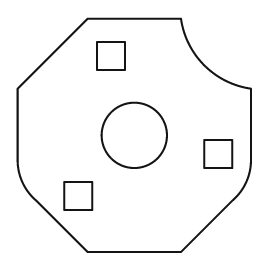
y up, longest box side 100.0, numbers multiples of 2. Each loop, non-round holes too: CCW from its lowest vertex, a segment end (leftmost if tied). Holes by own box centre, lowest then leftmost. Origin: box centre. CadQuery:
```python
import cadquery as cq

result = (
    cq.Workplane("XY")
    .moveTo(-20.0, -50.0)
    .lineTo(20.0, -50.0)
    .lineTo(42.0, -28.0)
    .threePointArc((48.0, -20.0), (50.0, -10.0))
    .lineTo(50.0, 20.0)
    .threePointArc((30.0, 30.0), (20.0, 50.0))
    .lineTo(-20.0, 50.0)
    .lineTo(-50.0, 20.0)
    .lineTo(-50.0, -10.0)
    .threePointArc((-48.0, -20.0), (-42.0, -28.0))
    .close()
    .moveTo(-30.0, -32.0)
    .lineTo(-18.0, -32.0)
    .lineTo(-18.0, -20.0)
    .lineTo(-30.0, -20.0)
    .close()
    .moveTo(30.0, -14.0)
    .lineTo(42.0, -14.0)
    .lineTo(42.0, -2.0)
    .lineTo(30.0, -2.0)
    .close()
    .moveTo(0.0, 0.0)
    .circle(14.0)
    .moveTo(-16.0, 28.0)
    .lineTo(-4.0, 28.0)
    .lineTo(-4.0, 40.0)
    .lineTo(-16.0, 40.0)
    .close()
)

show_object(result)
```